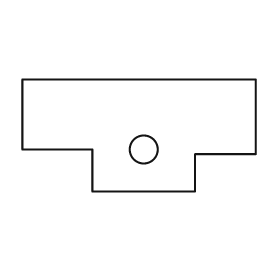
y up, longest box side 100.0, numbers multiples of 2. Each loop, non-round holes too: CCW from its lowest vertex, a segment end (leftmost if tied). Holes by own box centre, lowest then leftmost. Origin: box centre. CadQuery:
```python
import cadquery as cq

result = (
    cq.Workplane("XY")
    .moveTo(-20.0, -24.0)
    .lineTo(24.0, -24.0)
    .lineTo(24.0, -8.0)
    .lineTo(50.0, -8.0)
    .lineTo(50.0, 24.0)
    .lineTo(-50.0, 24.0)
    .lineTo(-50.0, -6.0)
    .lineTo(-20.0, -6.0)
    .close()
    .moveTo(2.0, -6.0)
    .circle(6.0)
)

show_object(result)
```